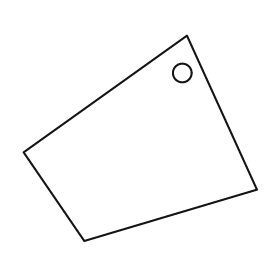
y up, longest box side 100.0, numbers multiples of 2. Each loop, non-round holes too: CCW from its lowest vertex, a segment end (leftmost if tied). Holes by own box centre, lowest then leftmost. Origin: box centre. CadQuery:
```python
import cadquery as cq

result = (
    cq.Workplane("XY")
    .moveTo(-24.0, -44.0)
    .lineTo(50.0, -22.0)
    .lineTo(20.0, 44.0)
    .lineTo(-50.0, -6.0)
    .close()
    .moveTo(18.0, 28.0)
    .circle(4.0)
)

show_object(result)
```